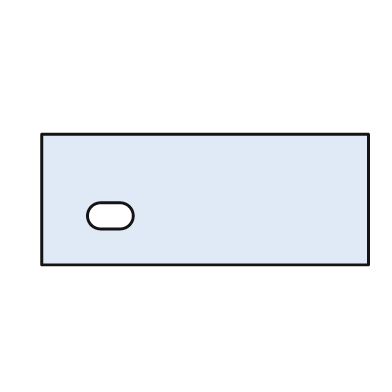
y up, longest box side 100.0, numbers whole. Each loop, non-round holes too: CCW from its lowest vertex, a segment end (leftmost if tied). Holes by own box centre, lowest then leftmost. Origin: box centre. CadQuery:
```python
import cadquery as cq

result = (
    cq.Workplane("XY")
    .moveTo(-50.0, -20.0)
    .lineTo(50.0, -20.0)
    .lineTo(50.0, 20.0)
    .lineTo(-50.0, 20.0)
    .close()
    .moveTo(-32.0, -9.0)
    .lineTo(-26.0, -9.0)
    .threePointArc((-22.0, -5.0), (-26.0, -1.0))
    .lineTo(-32.0, -1.0)
    .threePointArc((-36.0, -5.0), (-32.0, -9.0))
    .close()
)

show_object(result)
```